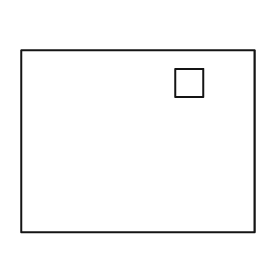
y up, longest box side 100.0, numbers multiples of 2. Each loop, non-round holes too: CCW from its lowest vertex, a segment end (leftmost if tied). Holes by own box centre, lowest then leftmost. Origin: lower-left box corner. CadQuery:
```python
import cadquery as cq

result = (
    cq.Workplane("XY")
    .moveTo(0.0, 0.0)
    .lineTo(100.0, 0.0)
    .lineTo(100.0, 78.0)
    .lineTo(0.0, 78.0)
    .close()
    .moveTo(66.0, 58.0)
    .lineTo(78.0, 58.0)
    .lineTo(78.0, 70.0)
    .lineTo(66.0, 70.0)
    .close()
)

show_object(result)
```